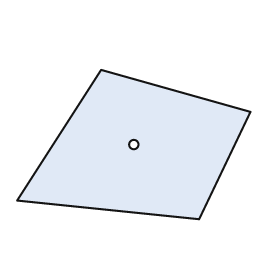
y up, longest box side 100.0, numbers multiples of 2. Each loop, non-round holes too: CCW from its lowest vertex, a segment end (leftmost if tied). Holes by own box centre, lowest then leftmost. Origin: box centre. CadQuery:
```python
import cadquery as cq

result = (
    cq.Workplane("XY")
    .moveTo(28.0, -32.0)
    .lineTo(50.0, 14.0)
    .lineTo(-14.0, 32.0)
    .lineTo(-50.0, -24.0)
    .close()
    .moveTo(0.0, 0.0)
    .circle(2.0)
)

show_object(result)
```